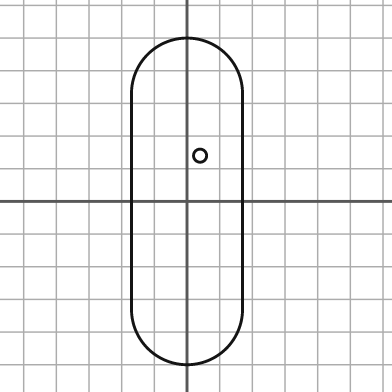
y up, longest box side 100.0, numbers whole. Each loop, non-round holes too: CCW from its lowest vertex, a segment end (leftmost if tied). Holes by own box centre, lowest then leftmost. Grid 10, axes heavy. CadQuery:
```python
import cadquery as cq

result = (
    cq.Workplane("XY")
    .moveTo(-17.0, -33.0)
    .threePointArc((0.0, -50.0), (17.0, -33.0))
    .lineTo(17.0, 33.0)
    .threePointArc((0.0, 50.0), (-17.0, 33.0))
    .close()
    .moveTo(4.0, 14.0)
    .circle(2.0)
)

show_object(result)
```